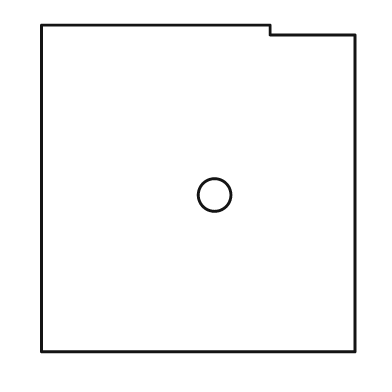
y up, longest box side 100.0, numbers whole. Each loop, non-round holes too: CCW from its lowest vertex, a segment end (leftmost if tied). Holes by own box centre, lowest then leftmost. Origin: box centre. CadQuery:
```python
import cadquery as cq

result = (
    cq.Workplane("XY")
    .moveTo(-48.0, -50.0)
    .lineTo(48.0, -50.0)
    .lineTo(48.0, 47.0)
    .lineTo(22.0, 47.0)
    .lineTo(22.0, 50.0)
    .lineTo(-48.0, 50.0)
    .close()
    .moveTo(5.0, -2.0)
    .circle(5.0)
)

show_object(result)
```